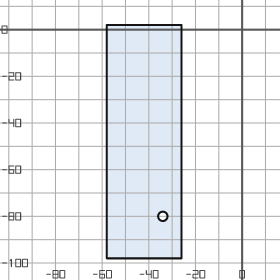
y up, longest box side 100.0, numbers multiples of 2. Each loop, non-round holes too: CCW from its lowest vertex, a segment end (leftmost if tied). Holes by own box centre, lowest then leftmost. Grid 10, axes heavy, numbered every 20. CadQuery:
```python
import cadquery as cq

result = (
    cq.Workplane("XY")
    .moveTo(-58.0, -98.0)
    .lineTo(-26.0, -98.0)
    .lineTo(-26.0, 2.0)
    .lineTo(-58.0, 2.0)
    .close()
    .moveTo(-34.0, -80.0)
    .circle(2.0)
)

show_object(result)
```